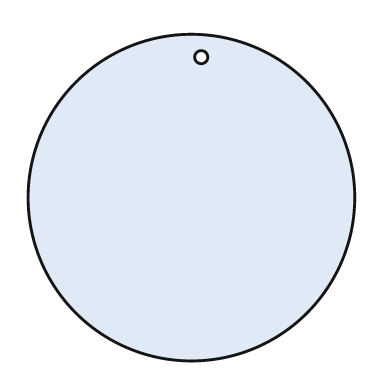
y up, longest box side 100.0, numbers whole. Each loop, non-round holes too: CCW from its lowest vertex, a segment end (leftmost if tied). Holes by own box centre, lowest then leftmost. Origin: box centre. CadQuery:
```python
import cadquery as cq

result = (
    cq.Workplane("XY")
    .moveTo(0.0, 0.0)
    .circle(50.0)
    .moveTo(3.0, 43.0)
    .circle(2.0)
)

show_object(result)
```